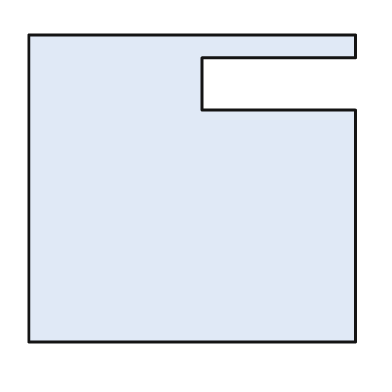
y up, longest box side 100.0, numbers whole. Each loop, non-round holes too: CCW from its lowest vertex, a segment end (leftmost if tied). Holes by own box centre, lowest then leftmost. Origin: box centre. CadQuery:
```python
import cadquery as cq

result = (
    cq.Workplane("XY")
    .moveTo(-50.0, -47.0)
    .lineTo(50.0, -47.0)
    .lineTo(50.0, 24.0)
    .lineTo(3.0, 24.0)
    .lineTo(3.0, 40.0)
    .lineTo(50.0, 40.0)
    .lineTo(50.0, 47.0)
    .lineTo(-50.0, 47.0)
    .close()
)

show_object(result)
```